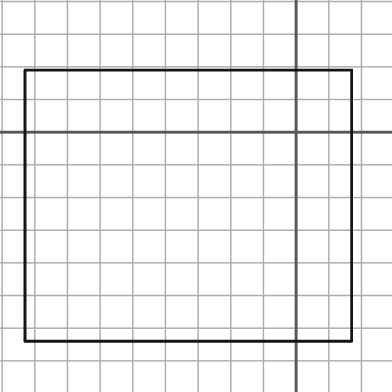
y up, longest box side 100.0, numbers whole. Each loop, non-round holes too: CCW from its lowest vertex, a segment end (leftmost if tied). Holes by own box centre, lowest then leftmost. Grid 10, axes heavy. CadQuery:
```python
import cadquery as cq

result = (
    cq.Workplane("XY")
    .moveTo(-83.0, -64.0)
    .lineTo(17.0, -64.0)
    .lineTo(17.0, 19.0)
    .lineTo(-83.0, 19.0)
    .close()
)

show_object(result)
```